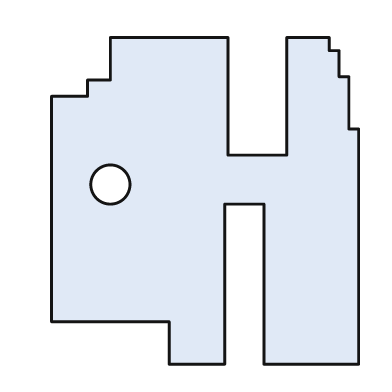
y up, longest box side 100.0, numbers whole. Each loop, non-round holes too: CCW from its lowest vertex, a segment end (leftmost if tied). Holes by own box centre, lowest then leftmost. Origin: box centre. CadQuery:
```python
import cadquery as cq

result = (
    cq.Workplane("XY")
    .moveTo(-11.0, -50.0)
    .lineTo(6.0, -50.0)
    .lineTo(6.0, -1.0)
    .lineTo(18.0, -1.0)
    .lineTo(18.0, -50.0)
    .lineTo(47.0, -50.0)
    .lineTo(47.0, 22.0)
    .lineTo(44.0, 22.0)
    .lineTo(44.0, 38.0)
    .lineTo(41.0, 38.0)
    .lineTo(41.0, 46.0)
    .lineTo(38.0, 46.0)
    .lineTo(38.0, 50.0)
    .lineTo(25.0, 50.0)
    .lineTo(25.0, 14.0)
    .lineTo(7.0, 14.0)
    .lineTo(7.0, 50.0)
    .lineTo(-29.0, 50.0)
    .lineTo(-29.0, 37.0)
    .lineTo(-36.0, 37.0)
    .lineTo(-36.0, 32.0)
    .lineTo(-47.0, 32.0)
    .lineTo(-47.0, -37.0)
    .lineTo(-11.0, -37.0)
    .close()
    .moveTo(-29.0, 5.0)
    .circle(6.0)
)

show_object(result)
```